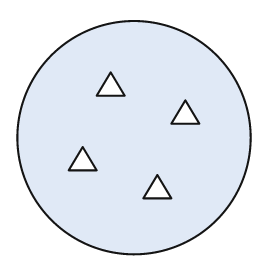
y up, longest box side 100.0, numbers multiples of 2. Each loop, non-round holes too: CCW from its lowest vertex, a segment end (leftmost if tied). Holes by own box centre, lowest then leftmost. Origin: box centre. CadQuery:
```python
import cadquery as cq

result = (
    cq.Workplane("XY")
    .moveTo(0.0, 0.0)
    .circle(50.0)
    .moveTo(4.0, -26.0)
    .lineTo(16.0, -26.0)
    .lineTo(10.0, -16.0)
    .close()
    .moveTo(-28.0, -14.0)
    .lineTo(-16.0, -14.0)
    .lineTo(-22.0, -4.0)
    .close()
    .moveTo(16.0, 6.0)
    .lineTo(28.0, 6.0)
    .lineTo(22.0, 16.0)
    .close()
    .moveTo(-16.0, 18.0)
    .lineTo(-4.0, 18.0)
    .lineTo(-10.0, 28.0)
    .close()
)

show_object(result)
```